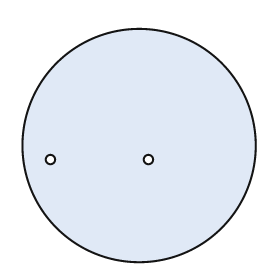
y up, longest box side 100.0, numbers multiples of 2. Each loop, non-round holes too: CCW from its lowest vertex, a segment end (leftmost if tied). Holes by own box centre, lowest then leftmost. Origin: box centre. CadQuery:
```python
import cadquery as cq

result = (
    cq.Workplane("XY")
    .moveTo(0.0, 0.0)
    .circle(50.0)
    .moveTo(-38.0, -6.0)
    .circle(2.0)
    .moveTo(4.0, -6.0)
    .circle(2.0)
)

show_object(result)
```